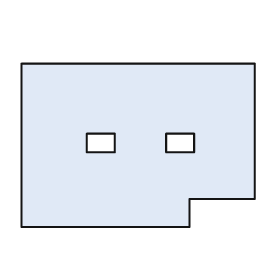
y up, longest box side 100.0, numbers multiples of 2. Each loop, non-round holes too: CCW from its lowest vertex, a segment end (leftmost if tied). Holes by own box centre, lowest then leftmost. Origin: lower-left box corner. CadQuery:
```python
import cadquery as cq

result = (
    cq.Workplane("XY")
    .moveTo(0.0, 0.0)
    .lineTo(72.0, 0.0)
    .lineTo(72.0, 12.0)
    .lineTo(100.0, 12.0)
    .lineTo(100.0, 70.0)
    .lineTo(0.0, 70.0)
    .close()
    .moveTo(28.0, 32.0)
    .lineTo(40.0, 32.0)
    .lineTo(40.0, 40.0)
    .lineTo(28.0, 40.0)
    .close()
    .moveTo(62.0, 32.0)
    .lineTo(74.0, 32.0)
    .lineTo(74.0, 40.0)
    .lineTo(62.0, 40.0)
    .close()
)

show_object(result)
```